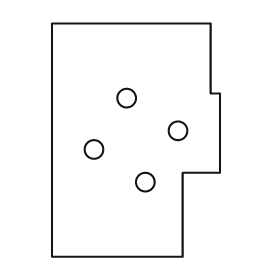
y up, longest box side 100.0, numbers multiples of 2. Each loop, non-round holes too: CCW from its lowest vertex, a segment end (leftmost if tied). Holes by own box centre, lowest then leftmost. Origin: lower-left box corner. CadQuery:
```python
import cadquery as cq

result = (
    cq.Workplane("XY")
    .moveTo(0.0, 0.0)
    .lineTo(56.0, 0.0)
    .lineTo(56.0, 36.0)
    .lineTo(72.0, 36.0)
    .lineTo(72.0, 70.0)
    .lineTo(68.0, 70.0)
    .lineTo(68.0, 100.0)
    .lineTo(0.0, 100.0)
    .close()
    .moveTo(40.0, 32.0)
    .circle(4.0)
    .moveTo(18.0, 46.0)
    .circle(4.0)
    .moveTo(54.0, 54.0)
    .circle(4.0)
    .moveTo(32.0, 68.0)
    .circle(4.0)
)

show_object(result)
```